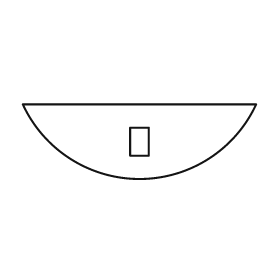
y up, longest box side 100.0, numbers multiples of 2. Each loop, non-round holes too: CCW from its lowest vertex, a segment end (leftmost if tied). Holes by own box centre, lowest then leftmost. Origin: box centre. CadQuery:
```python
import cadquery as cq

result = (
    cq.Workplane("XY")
    .moveTo(-50.0, 16.0)
    .threePointArc((0.0, -16.0), (50.0, 16.0))
    .close()
    .moveTo(-4.0, -6.0)
    .lineTo(4.0, -6.0)
    .lineTo(4.0, 6.0)
    .lineTo(-4.0, 6.0)
    .close()
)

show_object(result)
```